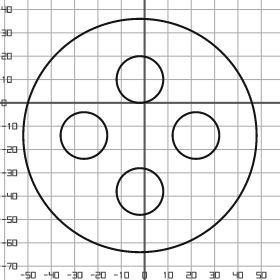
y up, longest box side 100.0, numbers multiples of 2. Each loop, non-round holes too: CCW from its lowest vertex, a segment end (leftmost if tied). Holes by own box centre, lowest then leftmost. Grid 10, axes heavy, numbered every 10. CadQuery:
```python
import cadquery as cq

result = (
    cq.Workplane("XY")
    .moveTo(-2.0, -14.0)
    .circle(50.0)
    .moveTo(-2.0, -38.0)
    .circle(10.0)
    .moveTo(-26.0, -14.0)
    .circle(10.0)
    .moveTo(22.0, -14.0)
    .circle(10.0)
    .moveTo(-2.0, 10.0)
    .circle(10.0)
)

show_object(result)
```